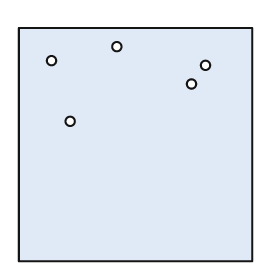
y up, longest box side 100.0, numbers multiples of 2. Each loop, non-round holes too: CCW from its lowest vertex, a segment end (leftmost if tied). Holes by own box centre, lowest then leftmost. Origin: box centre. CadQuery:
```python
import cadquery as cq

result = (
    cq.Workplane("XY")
    .moveTo(-50.0, -50.0)
    .lineTo(50.0, -50.0)
    .lineTo(50.0, 50.0)
    .lineTo(-50.0, 50.0)
    .close()
    .moveTo(-28.0, 10.0)
    .circle(2.0)
    .moveTo(24.0, 26.0)
    .circle(2.0)
    .moveTo(30.0, 34.0)
    .circle(2.0)
    .moveTo(-36.0, 36.0)
    .circle(2.0)
    .moveTo(-8.0, 42.0)
    .circle(2.0)
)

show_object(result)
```